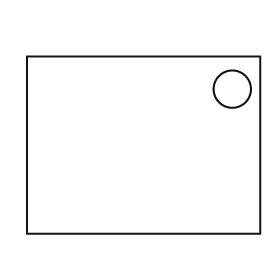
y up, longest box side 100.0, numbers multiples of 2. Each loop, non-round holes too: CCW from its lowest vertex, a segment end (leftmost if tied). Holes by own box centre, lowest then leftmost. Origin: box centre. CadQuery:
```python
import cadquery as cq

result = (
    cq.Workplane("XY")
    .moveTo(-50.0, -38.0)
    .lineTo(50.0, -38.0)
    .lineTo(50.0, 38.0)
    .lineTo(-50.0, 38.0)
    .close()
    .moveTo(38.0, 24.0)
    .circle(8.0)
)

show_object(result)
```